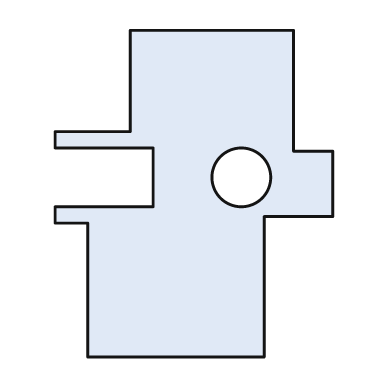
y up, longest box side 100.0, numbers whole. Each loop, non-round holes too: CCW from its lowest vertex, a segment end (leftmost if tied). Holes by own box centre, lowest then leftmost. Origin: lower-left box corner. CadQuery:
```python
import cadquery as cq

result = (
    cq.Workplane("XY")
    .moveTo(10.0, 0.0)
    .lineTo(64.0, 0.0)
    .lineTo(64.0, 43.0)
    .lineTo(85.0, 43.0)
    .lineTo(85.0, 63.0)
    .lineTo(73.0, 63.0)
    .lineTo(73.0, 100.0)
    .lineTo(23.0, 100.0)
    .lineTo(23.0, 69.0)
    .lineTo(0.0, 69.0)
    .lineTo(0.0, 64.0)
    .lineTo(30.0, 64.0)
    .lineTo(30.0, 46.0)
    .lineTo(0.0, 46.0)
    .lineTo(0.0, 41.0)
    .lineTo(10.0, 41.0)
    .close()
    .moveTo(57.0, 55.0)
    .circle(9.0)
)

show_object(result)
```